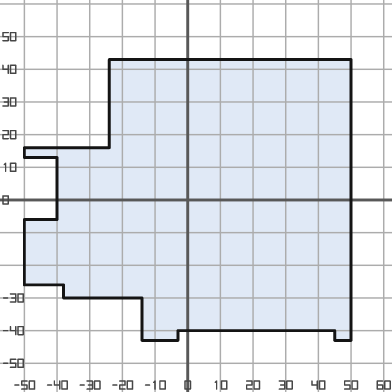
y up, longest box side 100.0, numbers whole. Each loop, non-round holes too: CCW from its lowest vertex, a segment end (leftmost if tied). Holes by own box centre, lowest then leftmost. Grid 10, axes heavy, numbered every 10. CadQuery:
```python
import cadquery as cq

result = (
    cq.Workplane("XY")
    .moveTo(-14.0, -43.0)
    .lineTo(-3.0, -43.0)
    .lineTo(-3.0, -40.0)
    .lineTo(45.0, -40.0)
    .lineTo(45.0, -43.0)
    .lineTo(50.0, -43.0)
    .lineTo(50.0, 43.0)
    .lineTo(-24.0, 43.0)
    .lineTo(-24.0, 16.0)
    .lineTo(-50.0, 16.0)
    .lineTo(-50.0, 13.0)
    .lineTo(-40.0, 13.0)
    .lineTo(-40.0, -6.0)
    .lineTo(-50.0, -6.0)
    .lineTo(-50.0, -26.0)
    .lineTo(-38.0, -26.0)
    .lineTo(-38.0, -30.0)
    .lineTo(-14.0, -30.0)
    .close()
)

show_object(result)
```